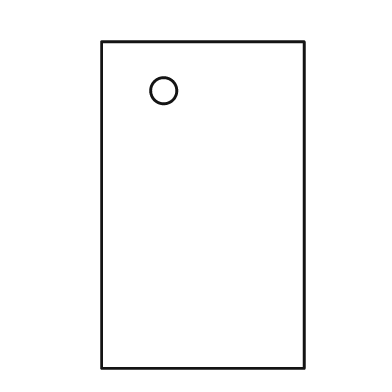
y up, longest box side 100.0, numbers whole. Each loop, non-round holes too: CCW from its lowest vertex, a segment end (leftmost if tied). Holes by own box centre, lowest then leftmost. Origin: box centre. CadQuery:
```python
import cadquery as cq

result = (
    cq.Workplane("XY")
    .moveTo(-31.0, -50.0)
    .lineTo(31.0, -50.0)
    .lineTo(31.0, 50.0)
    .lineTo(-31.0, 50.0)
    .close()
    .moveTo(-12.0, 35.0)
    .circle(4.0)
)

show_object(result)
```